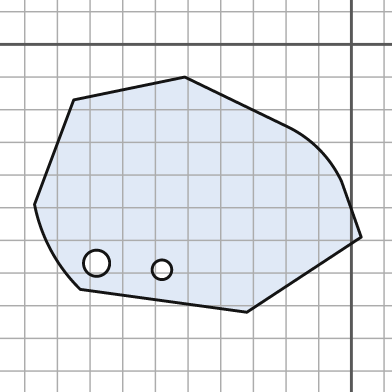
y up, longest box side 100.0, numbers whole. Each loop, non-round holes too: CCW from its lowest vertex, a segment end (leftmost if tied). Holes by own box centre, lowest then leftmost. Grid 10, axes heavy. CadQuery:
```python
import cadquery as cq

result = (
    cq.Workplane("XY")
    .moveTo(-32.0, -82.0)
    .lineTo(3.0, -59.0)
    .lineTo(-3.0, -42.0)
    .threePointArc((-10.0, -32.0), (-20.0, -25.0))
    .lineTo(-51.0, -10.0)
    .lineTo(-85.0, -17.0)
    .lineTo(-97.0, -49.0)
    .threePointArc((-92.0, -63.0), (-83.0, -75.0))
    .close()
    .moveTo(-58.0, -69.0)
    .circle(3.0)
    .moveTo(-78.0, -67.0)
    .circle(4.0)
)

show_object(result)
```